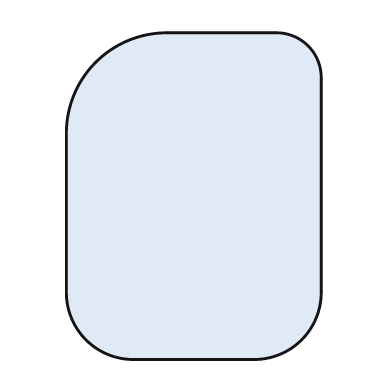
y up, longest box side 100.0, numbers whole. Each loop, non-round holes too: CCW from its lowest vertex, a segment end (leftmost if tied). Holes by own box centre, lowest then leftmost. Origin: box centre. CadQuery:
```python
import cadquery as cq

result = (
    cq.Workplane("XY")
    .moveTo(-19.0, -50.0)
    .lineTo(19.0, -50.0)
    .threePointArc((33.0, -44.0), (39.0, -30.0))
    .lineTo(39.0, 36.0)
    .threePointArc((35.0, 46.0), (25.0, 50.0))
    .lineTo(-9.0, 50.0)
    .threePointArc((-30.0, 41.0), (-39.0, 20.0))
    .lineTo(-39.0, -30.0)
    .threePointArc((-33.0, -44.0), (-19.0, -50.0))
    .close()
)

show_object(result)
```